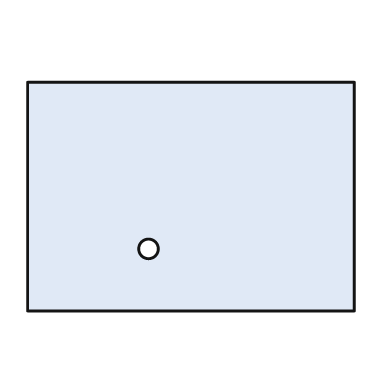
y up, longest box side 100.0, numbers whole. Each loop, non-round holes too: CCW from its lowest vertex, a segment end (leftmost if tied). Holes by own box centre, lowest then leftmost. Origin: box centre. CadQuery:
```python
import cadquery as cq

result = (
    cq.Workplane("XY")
    .moveTo(-50.0, -35.0)
    .lineTo(50.0, -35.0)
    .lineTo(50.0, 35.0)
    .lineTo(-50.0, 35.0)
    .close()
    .moveTo(-13.0, -16.0)
    .circle(3.0)
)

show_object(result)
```